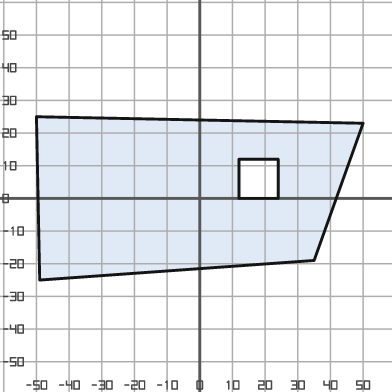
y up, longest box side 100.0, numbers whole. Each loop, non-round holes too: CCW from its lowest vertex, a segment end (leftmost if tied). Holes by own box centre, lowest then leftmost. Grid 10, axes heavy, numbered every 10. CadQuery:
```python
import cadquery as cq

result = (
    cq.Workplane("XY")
    .moveTo(-49.0, -25.0)
    .lineTo(35.0, -19.0)
    .lineTo(50.0, 23.0)
    .lineTo(-50.0, 25.0)
    .close()
    .moveTo(12.0, 0.0)
    .lineTo(24.0, 0.0)
    .lineTo(24.0, 12.0)
    .lineTo(12.0, 12.0)
    .close()
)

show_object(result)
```